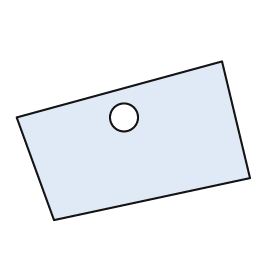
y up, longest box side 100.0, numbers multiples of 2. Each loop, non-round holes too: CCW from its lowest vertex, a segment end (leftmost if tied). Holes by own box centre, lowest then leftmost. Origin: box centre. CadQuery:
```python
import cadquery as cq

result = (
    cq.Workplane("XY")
    .moveTo(-34.0, -34.0)
    .lineTo(50.0, -16.0)
    .lineTo(38.0, 34.0)
    .lineTo(-50.0, 10.0)
    .close()
    .moveTo(-4.0, 10.0)
    .circle(6.0)
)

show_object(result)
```